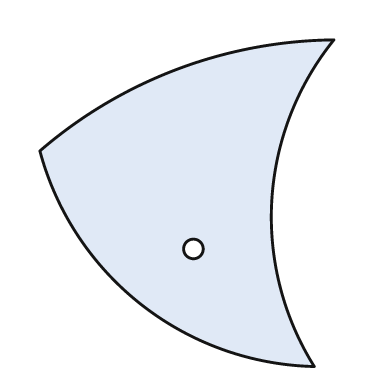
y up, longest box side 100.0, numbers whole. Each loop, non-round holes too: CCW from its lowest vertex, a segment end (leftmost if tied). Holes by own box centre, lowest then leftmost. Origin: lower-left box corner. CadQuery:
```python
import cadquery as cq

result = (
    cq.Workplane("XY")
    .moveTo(84.0, 0.0)
    .threePointArc((71.0, 51.0), (90.0, 100.0))
    .threePointArc((42.0, 91.0), (0.0, 66.0))
    .threePointArc((31.0, 19.0), (84.0, 0.0))
    .close()
    .moveTo(47.0, 36.0)
    .circle(3.0)
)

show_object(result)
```